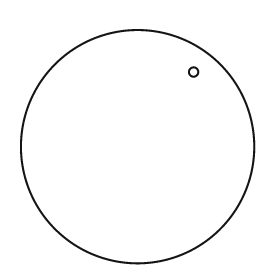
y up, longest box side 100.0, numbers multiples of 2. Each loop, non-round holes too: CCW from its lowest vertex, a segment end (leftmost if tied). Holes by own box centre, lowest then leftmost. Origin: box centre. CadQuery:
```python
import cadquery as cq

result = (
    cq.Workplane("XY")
    .moveTo(0.0, 0.0)
    .circle(50.0)
    .moveTo(24.0, 32.0)
    .circle(2.0)
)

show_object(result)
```